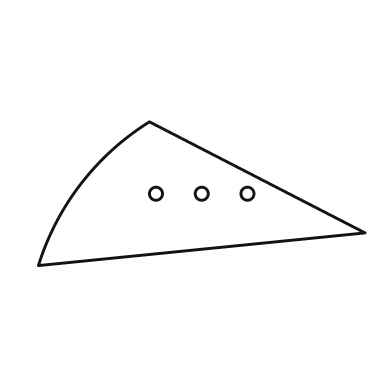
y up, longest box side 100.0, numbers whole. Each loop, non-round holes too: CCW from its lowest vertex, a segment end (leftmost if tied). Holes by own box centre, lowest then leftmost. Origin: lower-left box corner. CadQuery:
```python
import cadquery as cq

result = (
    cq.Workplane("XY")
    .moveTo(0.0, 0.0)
    .lineTo(100.0, 10.0)
    .lineTo(34.0, 44.0)
    .threePointArc((13.0, 25.0), (0.0, 0.0))
    .close()
    .moveTo(36.0, 22.0)
    .circle(2.0)
    .moveTo(50.0, 22.0)
    .circle(2.0)
    .moveTo(64.0, 22.0)
    .circle(2.0)
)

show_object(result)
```